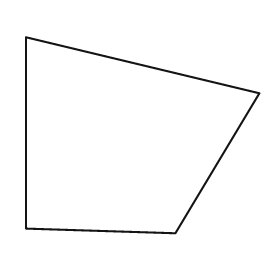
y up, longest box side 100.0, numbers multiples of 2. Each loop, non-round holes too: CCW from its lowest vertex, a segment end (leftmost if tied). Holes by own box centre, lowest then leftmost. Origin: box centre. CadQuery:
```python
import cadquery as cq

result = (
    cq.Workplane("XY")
    .moveTo(14.0, -42.0)
    .lineTo(50.0, 18.0)
    .lineTo(-50.0, 42.0)
    .lineTo(-50.0, -40.0)
    .close()
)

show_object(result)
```